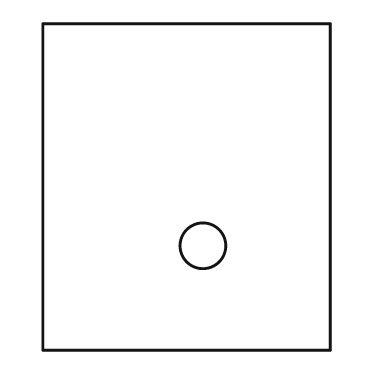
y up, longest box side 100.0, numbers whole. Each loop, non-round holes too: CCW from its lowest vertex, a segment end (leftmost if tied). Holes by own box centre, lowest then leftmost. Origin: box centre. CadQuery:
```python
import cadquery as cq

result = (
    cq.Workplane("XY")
    .moveTo(-44.0, -50.0)
    .lineTo(44.0, -50.0)
    .lineTo(44.0, 50.0)
    .lineTo(-44.0, 50.0)
    .close()
    .moveTo(5.0, -18.0)
    .circle(7.0)
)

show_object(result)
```